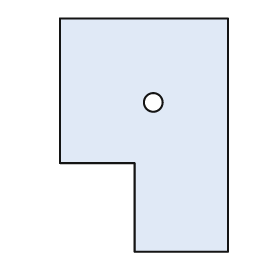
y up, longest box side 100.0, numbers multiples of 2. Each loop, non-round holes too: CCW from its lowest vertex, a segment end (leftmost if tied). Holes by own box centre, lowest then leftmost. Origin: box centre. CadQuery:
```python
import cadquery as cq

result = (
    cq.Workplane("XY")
    .moveTo(-4.0, -50.0)
    .lineTo(36.0, -50.0)
    .lineTo(36.0, 50.0)
    .lineTo(-36.0, 50.0)
    .lineTo(-36.0, -12.0)
    .lineTo(-4.0, -12.0)
    .close()
    .moveTo(4.0, 14.0)
    .circle(4.0)
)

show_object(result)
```